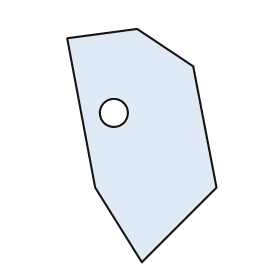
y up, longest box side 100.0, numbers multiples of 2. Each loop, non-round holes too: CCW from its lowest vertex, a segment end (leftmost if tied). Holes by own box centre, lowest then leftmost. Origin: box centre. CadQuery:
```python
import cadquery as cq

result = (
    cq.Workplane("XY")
    .moveTo(0.0, -50.0)
    .lineTo(32.0, -18.0)
    .lineTo(22.0, 34.0)
    .lineTo(-2.0, 50.0)
    .lineTo(-32.0, 46.0)
    .lineTo(-20.0, -18.0)
    .close()
    .moveTo(-12.0, 14.0)
    .circle(6.0)
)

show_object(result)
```